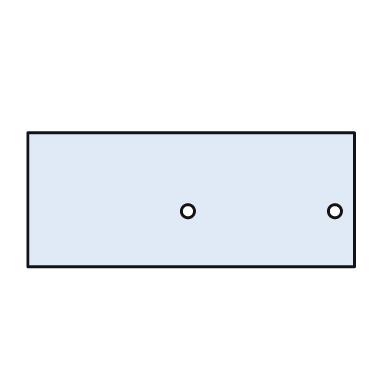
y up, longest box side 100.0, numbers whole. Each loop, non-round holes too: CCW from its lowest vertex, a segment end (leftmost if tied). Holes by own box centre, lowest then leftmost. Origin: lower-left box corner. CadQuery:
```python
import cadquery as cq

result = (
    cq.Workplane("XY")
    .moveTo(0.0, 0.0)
    .lineTo(100.0, 0.0)
    .lineTo(100.0, 41.0)
    .lineTo(0.0, 41.0)
    .close()
    .moveTo(49.0, 17.0)
    .circle(2.0)
    .moveTo(94.0, 17.0)
    .circle(2.0)
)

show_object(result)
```